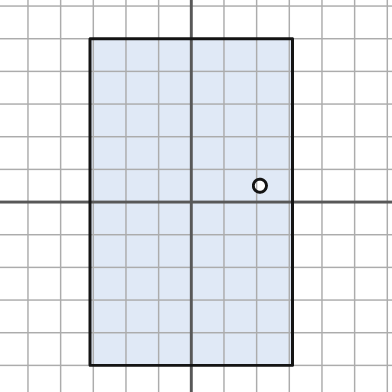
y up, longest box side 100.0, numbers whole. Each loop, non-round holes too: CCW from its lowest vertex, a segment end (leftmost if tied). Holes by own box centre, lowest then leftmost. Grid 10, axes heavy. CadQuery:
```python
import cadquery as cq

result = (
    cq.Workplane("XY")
    .moveTo(-31.0, -50.0)
    .lineTo(31.0, -50.0)
    .lineTo(31.0, 50.0)
    .lineTo(-31.0, 50.0)
    .close()
    .moveTo(21.0, 5.0)
    .circle(2.0)
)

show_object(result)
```